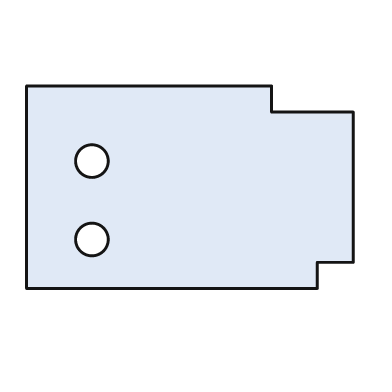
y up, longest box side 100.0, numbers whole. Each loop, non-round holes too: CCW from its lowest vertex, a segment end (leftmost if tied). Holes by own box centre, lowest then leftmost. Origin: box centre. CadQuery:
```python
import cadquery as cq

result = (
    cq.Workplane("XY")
    .moveTo(-50.0, -31.0)
    .lineTo(39.0, -31.0)
    .lineTo(39.0, -23.0)
    .lineTo(50.0, -23.0)
    .lineTo(50.0, 23.0)
    .lineTo(25.0, 23.0)
    .lineTo(25.0, 31.0)
    .lineTo(-50.0, 31.0)
    .close()
    .moveTo(-30.0, -16.0)
    .circle(5.0)
    .moveTo(-30.0, 8.0)
    .circle(5.0)
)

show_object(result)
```